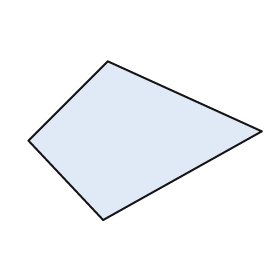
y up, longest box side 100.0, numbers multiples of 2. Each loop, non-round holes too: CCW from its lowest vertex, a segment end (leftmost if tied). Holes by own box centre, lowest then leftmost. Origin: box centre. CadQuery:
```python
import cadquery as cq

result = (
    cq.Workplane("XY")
    .moveTo(-18.0, -34.0)
    .lineTo(50.0, 4.0)
    .lineTo(-16.0, 34.0)
    .lineTo(-50.0, 0.0)
    .close()
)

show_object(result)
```